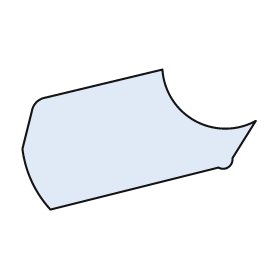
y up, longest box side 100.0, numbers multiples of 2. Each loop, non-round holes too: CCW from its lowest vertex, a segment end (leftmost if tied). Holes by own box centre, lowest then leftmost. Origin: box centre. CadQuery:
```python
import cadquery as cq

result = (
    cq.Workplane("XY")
    .moveTo(-38.0, -30.0)
    .lineTo(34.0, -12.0)
    .threePointArc((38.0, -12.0), (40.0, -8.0))
    .lineTo(50.0, 8.0)
    .threePointArc((24.0, 8.0), (10.0, 30.0))
    .lineTo(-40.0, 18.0)
    .threePointArc((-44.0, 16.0), (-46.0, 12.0))
    .lineTo(-50.0, -4.0)
    .threePointArc((-46.0, -18.0), (-38.0, -30.0))
    .close()
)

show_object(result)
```